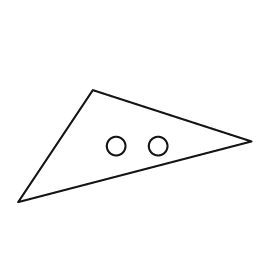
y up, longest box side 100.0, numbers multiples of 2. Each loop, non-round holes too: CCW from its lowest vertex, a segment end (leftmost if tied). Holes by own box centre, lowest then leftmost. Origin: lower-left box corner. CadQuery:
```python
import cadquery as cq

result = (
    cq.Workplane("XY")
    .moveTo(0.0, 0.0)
    .lineTo(100.0, 26.0)
    .lineTo(32.0, 48.0)
    .close()
    .moveTo(42.0, 24.0)
    .circle(4.0)
    .moveTo(60.0, 24.0)
    .circle(4.0)
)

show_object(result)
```